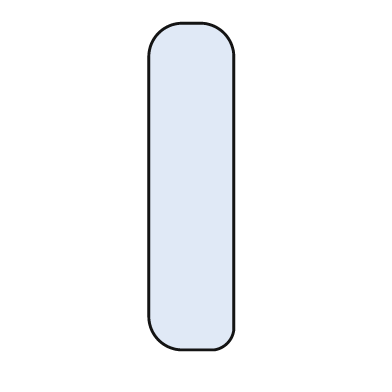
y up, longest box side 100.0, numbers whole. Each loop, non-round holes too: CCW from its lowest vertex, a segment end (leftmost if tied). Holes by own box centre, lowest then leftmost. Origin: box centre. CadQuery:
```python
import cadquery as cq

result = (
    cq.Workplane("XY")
    .moveTo(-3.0, -50.0)
    .lineTo(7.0, -50.0)
    .threePointArc((11.0, -48.0), (13.0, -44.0))
    .lineTo(13.0, 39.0)
    .threePointArc((10.0, 47.0), (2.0, 50.0))
    .lineTo(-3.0, 50.0)
    .threePointArc((-10.0, 47.0), (-13.0, 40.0))
    .lineTo(-13.0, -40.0)
    .threePointArc((-10.0, -47.0), (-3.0, -50.0))
    .close()
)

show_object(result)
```